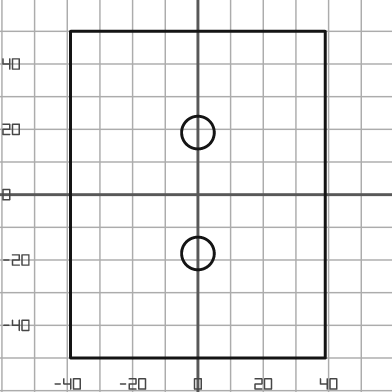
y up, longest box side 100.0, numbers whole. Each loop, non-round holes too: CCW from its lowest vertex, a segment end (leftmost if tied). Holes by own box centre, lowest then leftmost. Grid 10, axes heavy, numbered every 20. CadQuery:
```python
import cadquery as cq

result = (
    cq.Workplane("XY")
    .moveTo(-39.0, -50.0)
    .lineTo(39.0, -50.0)
    .lineTo(39.0, 50.0)
    .lineTo(-39.0, 50.0)
    .close()
    .moveTo(0.0, -18.0)
    .circle(5.0)
    .moveTo(0.0, 19.0)
    .circle(5.0)
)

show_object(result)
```